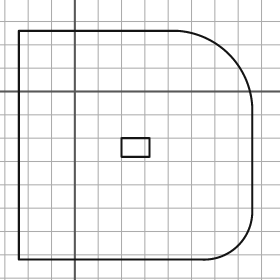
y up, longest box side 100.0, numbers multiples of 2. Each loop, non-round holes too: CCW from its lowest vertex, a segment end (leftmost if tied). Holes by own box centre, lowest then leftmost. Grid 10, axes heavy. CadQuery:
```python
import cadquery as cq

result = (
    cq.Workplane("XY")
    .moveTo(-24.0, -72.0)
    .lineTo(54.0, -72.0)
    .threePointArc((70.0, -66.0), (76.0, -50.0))
    .lineTo(76.0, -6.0)
    .threePointArc((66.0, 16.0), (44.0, 26.0))
    .lineTo(-24.0, 26.0)
    .close()
    .moveTo(20.0, -28.0)
    .lineTo(32.0, -28.0)
    .lineTo(32.0, -20.0)
    .lineTo(20.0, -20.0)
    .close()
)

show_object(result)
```